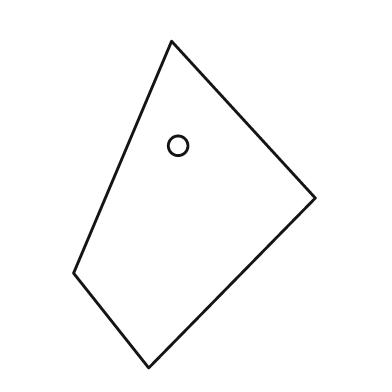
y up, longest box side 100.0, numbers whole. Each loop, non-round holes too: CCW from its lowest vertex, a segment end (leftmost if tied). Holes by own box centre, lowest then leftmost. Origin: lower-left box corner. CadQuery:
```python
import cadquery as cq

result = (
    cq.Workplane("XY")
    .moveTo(23.0, 0.0)
    .lineTo(74.0, 52.0)
    .lineTo(30.0, 100.0)
    .lineTo(0.0, 29.0)
    .close()
    .moveTo(32.0, 68.0)
    .circle(3.0)
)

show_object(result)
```